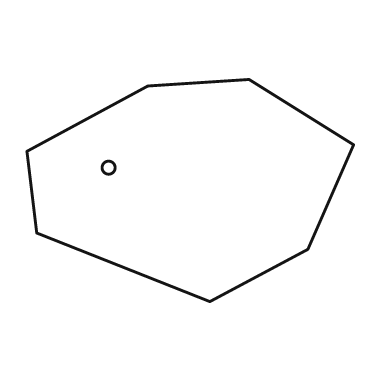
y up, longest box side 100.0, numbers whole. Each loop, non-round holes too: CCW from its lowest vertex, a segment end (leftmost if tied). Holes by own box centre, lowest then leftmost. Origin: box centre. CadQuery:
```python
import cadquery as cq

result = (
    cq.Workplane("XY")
    .moveTo(6.0, -34.0)
    .lineTo(36.0, -18.0)
    .lineTo(50.0, 14.0)
    .lineTo(18.0, 34.0)
    .lineTo(-13.0, 32.0)
    .lineTo(-50.0, 12.0)
    .lineTo(-47.0, -13.0)
    .close()
    .moveTo(-25.0, 7.0)
    .circle(2.0)
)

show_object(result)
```